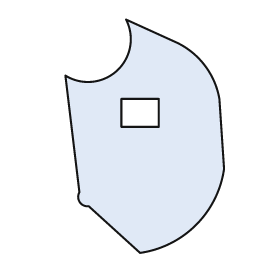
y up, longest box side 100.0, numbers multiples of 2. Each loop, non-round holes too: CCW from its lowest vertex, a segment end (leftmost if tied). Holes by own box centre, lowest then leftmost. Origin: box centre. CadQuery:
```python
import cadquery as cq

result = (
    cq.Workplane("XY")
    .moveTo(-2.0, -50.0)
    .threePointArc((22.0, -38.0), (34.0, -14.0))
    .lineTo(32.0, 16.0)
    .threePointArc((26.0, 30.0), (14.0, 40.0))
    .lineTo(-8.0, 50.0)
    .threePointArc((-12.0, 28.0), (-34.0, 26.0))
    .lineTo(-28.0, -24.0)
    .threePointArc((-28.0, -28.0), (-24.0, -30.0))
    .close()
    .moveTo(-10.0, 4.0)
    .lineTo(6.0, 4.0)
    .lineTo(6.0, 16.0)
    .lineTo(-10.0, 16.0)
    .close()
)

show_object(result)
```